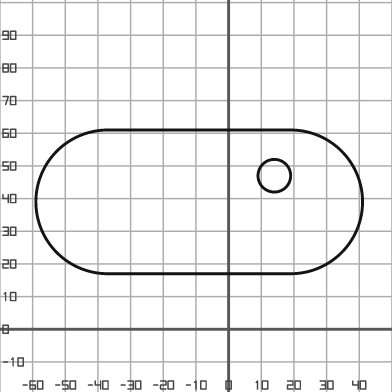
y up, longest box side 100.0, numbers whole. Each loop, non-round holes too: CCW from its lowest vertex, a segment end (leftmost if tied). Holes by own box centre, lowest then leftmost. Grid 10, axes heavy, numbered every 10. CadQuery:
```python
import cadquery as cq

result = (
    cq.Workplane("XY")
    .moveTo(-37.0, 17.0)
    .lineTo(19.0, 17.0)
    .threePointArc((41.0, 39.0), (19.0, 61.0))
    .lineTo(-37.0, 61.0)
    .threePointArc((-59.0, 39.0), (-37.0, 17.0))
    .close()
    .moveTo(14.0, 47.0)
    .circle(5.0)
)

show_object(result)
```